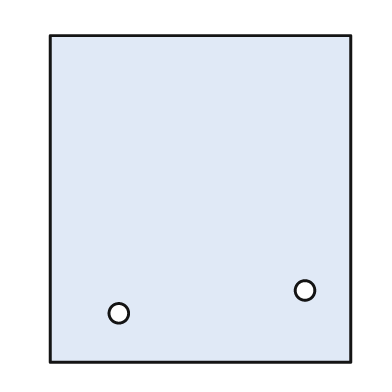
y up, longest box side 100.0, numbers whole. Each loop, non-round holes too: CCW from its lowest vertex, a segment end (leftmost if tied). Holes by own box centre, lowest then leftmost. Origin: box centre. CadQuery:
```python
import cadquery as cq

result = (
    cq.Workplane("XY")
    .moveTo(-46.0, -50.0)
    .lineTo(46.0, -50.0)
    .lineTo(46.0, 50.0)
    .lineTo(-46.0, 50.0)
    .close()
    .moveTo(-25.0, -35.0)
    .circle(3.0)
    .moveTo(32.0, -28.0)
    .circle(3.0)
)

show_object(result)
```